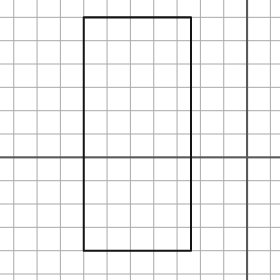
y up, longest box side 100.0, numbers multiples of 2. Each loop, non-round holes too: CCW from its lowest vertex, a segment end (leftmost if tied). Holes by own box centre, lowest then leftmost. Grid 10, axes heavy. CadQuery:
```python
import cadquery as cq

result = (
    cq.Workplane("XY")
    .moveTo(-70.0, -40.0)
    .lineTo(-24.0, -40.0)
    .lineTo(-24.0, 60.0)
    .lineTo(-70.0, 60.0)
    .close()
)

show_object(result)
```